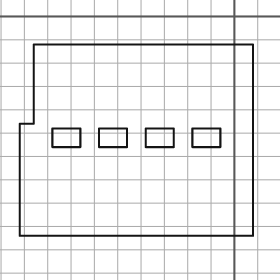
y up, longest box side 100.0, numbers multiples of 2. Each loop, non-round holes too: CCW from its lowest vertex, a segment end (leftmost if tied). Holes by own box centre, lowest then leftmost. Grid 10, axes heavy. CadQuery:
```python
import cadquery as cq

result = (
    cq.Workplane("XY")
    .moveTo(-92.0, -94.0)
    .lineTo(8.0, -94.0)
    .lineTo(8.0, -12.0)
    .lineTo(-86.0, -12.0)
    .lineTo(-86.0, -46.0)
    .lineTo(-92.0, -46.0)
    .close()
    .moveTo(-78.0, -56.0)
    .lineTo(-66.0, -56.0)
    .lineTo(-66.0, -48.0)
    .lineTo(-78.0, -48.0)
    .close()
    .moveTo(-58.0, -56.0)
    .lineTo(-46.0, -56.0)
    .lineTo(-46.0, -48.0)
    .lineTo(-58.0, -48.0)
    .close()
    .moveTo(-38.0, -56.0)
    .lineTo(-26.0, -56.0)
    .lineTo(-26.0, -48.0)
    .lineTo(-38.0, -48.0)
    .close()
    .moveTo(-18.0, -56.0)
    .lineTo(-6.0, -56.0)
    .lineTo(-6.0, -48.0)
    .lineTo(-18.0, -48.0)
    .close()
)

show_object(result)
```